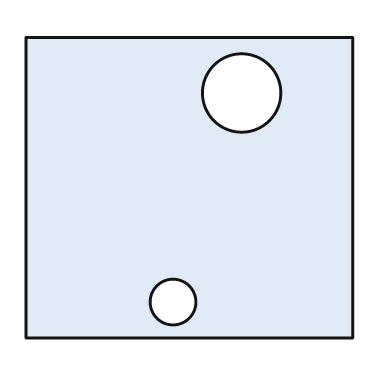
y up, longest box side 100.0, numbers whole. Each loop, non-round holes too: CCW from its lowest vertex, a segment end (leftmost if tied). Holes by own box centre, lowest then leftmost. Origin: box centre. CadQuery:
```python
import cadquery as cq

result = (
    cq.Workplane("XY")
    .moveTo(-50.0, -46.0)
    .lineTo(50.0, -46.0)
    .lineTo(50.0, 46.0)
    .lineTo(-50.0, 46.0)
    .close()
    .moveTo(-5.0, -35.0)
    .circle(7.0)
    .moveTo(16.0, 29.0)
    .circle(12.0)
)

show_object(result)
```